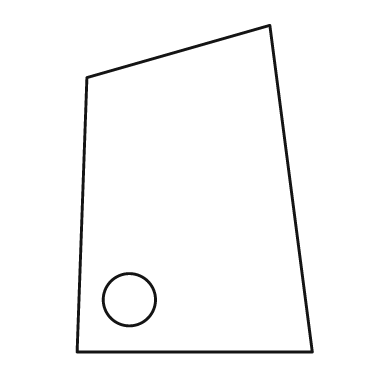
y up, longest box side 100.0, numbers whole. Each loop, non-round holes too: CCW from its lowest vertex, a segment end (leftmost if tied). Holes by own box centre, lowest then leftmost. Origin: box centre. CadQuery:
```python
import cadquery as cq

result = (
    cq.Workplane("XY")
    .moveTo(-36.0, -50.0)
    .lineTo(36.0, -50.0)
    .lineTo(23.0, 50.0)
    .lineTo(-33.0, 34.0)
    .close()
    .moveTo(-20.0, -34.0)
    .circle(8.0)
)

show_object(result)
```